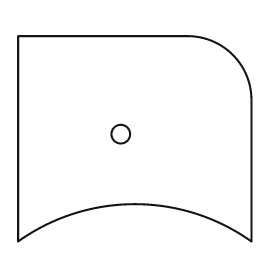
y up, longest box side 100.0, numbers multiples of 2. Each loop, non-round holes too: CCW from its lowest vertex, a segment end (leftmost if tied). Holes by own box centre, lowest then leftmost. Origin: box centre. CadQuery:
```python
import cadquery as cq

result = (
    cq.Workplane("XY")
    .moveTo(-50.0, -44.0)
    .threePointArc((0.0, -28.0), (50.0, -44.0))
    .lineTo(50.0, 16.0)
    .threePointArc((42.0, 36.0), (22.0, 44.0))
    .lineTo(-50.0, 44.0)
    .close()
    .moveTo(-6.0, 2.0)
    .circle(4.0)
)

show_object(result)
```